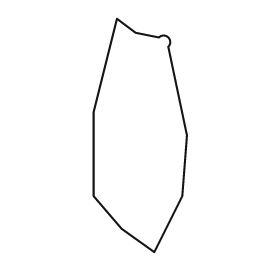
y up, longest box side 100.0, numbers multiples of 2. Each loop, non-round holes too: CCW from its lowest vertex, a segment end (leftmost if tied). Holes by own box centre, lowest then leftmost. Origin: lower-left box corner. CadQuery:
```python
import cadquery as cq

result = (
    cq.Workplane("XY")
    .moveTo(26.0, 0.0)
    .lineTo(38.0, 24.0)
    .lineTo(40.0, 50.0)
    .lineTo(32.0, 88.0)
    .threePointArc((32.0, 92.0), (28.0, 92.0))
    .lineTo(18.0, 94.0)
    .lineTo(10.0, 100.0)
    .lineTo(0.0, 60.0)
    .lineTo(0.0, 24.0)
    .lineTo(12.0, 10.0)
    .close()
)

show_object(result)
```